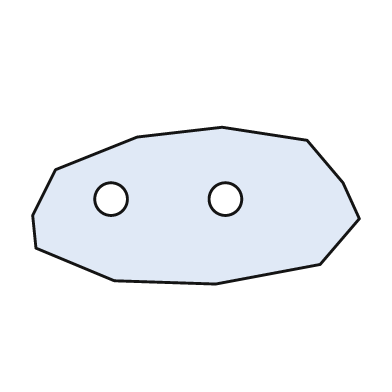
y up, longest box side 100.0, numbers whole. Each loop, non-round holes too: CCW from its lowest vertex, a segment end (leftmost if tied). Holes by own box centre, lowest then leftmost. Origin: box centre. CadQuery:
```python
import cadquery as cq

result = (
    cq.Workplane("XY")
    .moveTo(6.0, -24.0)
    .lineTo(38.0, -18.0)
    .lineTo(50.0, -4.0)
    .lineTo(45.0, 7.0)
    .lineTo(34.0, 20.0)
    .lineTo(8.0, 24.0)
    .lineTo(-18.0, 21.0)
    .lineTo(-43.0, 11.0)
    .lineTo(-50.0, -3.0)
    .lineTo(-49.0, -13.0)
    .lineTo(-25.0, -23.0)
    .close()
    .moveTo(-26.0, 2.0)
    .circle(5.0)
    .moveTo(9.0, 2.0)
    .circle(5.0)
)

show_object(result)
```